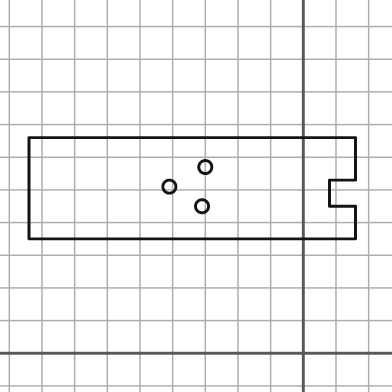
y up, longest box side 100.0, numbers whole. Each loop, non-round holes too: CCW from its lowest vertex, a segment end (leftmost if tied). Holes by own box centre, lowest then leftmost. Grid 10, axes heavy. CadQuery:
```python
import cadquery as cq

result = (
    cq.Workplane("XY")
    .moveTo(-84.0, 35.0)
    .lineTo(16.0, 35.0)
    .lineTo(16.0, 45.0)
    .lineTo(8.0, 45.0)
    .lineTo(8.0, 53.0)
    .lineTo(16.0, 53.0)
    .lineTo(16.0, 66.0)
    .lineTo(-84.0, 66.0)
    .close()
    .moveTo(-31.0, 45.0)
    .circle(2.0)
    .moveTo(-41.0, 51.0)
    .circle(2.0)
    .moveTo(-30.0, 57.0)
    .circle(2.0)
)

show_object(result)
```